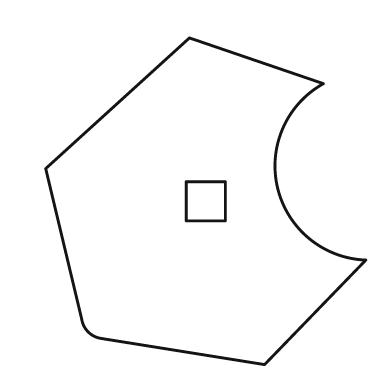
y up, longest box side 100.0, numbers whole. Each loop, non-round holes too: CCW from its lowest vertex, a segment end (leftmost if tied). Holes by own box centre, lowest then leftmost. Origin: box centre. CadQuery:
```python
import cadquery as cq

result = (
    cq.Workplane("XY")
    .moveTo(18.0, -50.0)
    .lineTo(49.0, -18.0)
    .threePointArc((22.0, 4.0), (36.0, 36.0))
    .lineTo(-5.0, 50.0)
    .lineTo(-49.0, 10.0)
    .lineTo(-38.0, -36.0)
    .threePointArc((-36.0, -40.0), (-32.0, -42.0))
    .close()
    .moveTo(-6.0, -6.0)
    .lineTo(6.0, -6.0)
    .lineTo(6.0, 6.0)
    .lineTo(-6.0, 6.0)
    .close()
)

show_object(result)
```